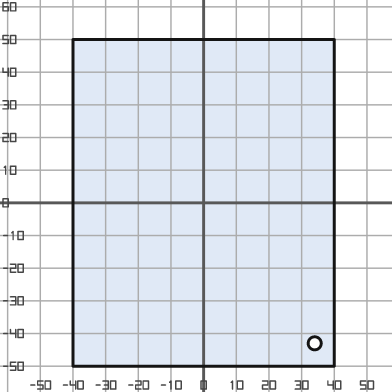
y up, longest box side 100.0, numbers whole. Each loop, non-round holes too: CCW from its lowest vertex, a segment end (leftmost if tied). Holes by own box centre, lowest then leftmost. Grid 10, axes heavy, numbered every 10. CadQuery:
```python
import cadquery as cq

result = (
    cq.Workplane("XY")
    .moveTo(-40.0, -50.0)
    .lineTo(40.0, -50.0)
    .lineTo(40.0, 50.0)
    .lineTo(-40.0, 50.0)
    .close()
    .moveTo(34.0, -43.0)
    .circle(2.0)
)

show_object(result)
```